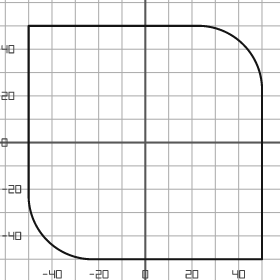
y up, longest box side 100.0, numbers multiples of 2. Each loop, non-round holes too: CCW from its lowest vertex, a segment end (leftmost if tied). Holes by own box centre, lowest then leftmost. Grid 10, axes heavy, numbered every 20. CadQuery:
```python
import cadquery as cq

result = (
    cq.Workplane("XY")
    .moveTo(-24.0, -50.0)
    .lineTo(50.0, -50.0)
    .lineTo(50.0, 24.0)
    .threePointArc((42.0, 42.0), (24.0, 50.0))
    .lineTo(-50.0, 50.0)
    .lineTo(-50.0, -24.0)
    .threePointArc((-42.0, -42.0), (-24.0, -50.0))
    .close()
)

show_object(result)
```